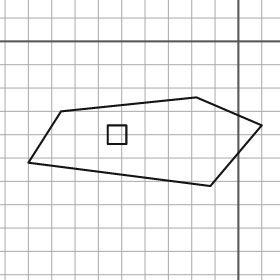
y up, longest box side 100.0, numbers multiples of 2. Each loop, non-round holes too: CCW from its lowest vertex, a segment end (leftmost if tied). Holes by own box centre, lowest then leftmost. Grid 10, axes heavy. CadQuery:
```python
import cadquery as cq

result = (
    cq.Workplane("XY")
    .moveTo(-12.0, -62.0)
    .lineTo(10.0, -36.0)
    .lineTo(-18.0, -24.0)
    .lineTo(-76.0, -30.0)
    .lineTo(-90.0, -52.0)
    .close()
    .moveTo(-56.0, -44.0)
    .lineTo(-48.0, -44.0)
    .lineTo(-48.0, -36.0)
    .lineTo(-56.0, -36.0)
    .close()
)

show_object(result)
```